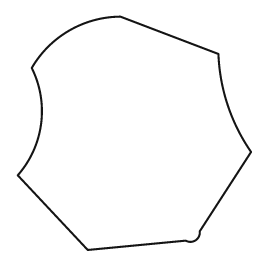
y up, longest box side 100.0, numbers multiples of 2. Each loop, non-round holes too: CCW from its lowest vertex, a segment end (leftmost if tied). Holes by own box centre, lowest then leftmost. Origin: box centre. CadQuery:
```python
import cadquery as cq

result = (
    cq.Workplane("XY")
    .moveTo(-20.0, -50.0)
    .lineTo(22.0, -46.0)
    .threePointArc((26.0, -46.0), (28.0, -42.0))
    .lineTo(50.0, -8.0)
    .threePointArc((40.0, 12.0), (36.0, 34.0))
    .lineTo(-6.0, 50.0)
    .threePointArc((-28.0, 44.0), (-44.0, 28.0))
    .threePointArc((-40.0, 4.0), (-50.0, -18.0))
    .close()
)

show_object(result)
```